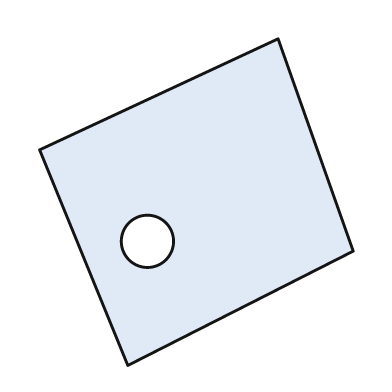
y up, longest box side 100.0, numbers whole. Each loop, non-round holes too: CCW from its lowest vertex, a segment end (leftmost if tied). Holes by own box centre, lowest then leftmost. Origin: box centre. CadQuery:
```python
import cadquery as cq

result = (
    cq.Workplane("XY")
    .moveTo(-21.0, -50.0)
    .lineTo(48.0, -15.0)
    .lineTo(25.0, 50.0)
    .lineTo(-48.0, 16.0)
    .close()
    .moveTo(-15.0, -12.0)
    .circle(8.0)
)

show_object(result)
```